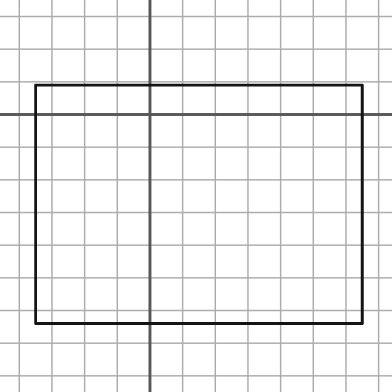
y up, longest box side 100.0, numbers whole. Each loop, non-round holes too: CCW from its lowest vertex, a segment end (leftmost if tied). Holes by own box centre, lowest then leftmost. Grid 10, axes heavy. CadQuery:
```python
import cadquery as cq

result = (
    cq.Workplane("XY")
    .moveTo(-35.0, -64.0)
    .lineTo(65.0, -64.0)
    .lineTo(65.0, 9.0)
    .lineTo(-35.0, 9.0)
    .close()
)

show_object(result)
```